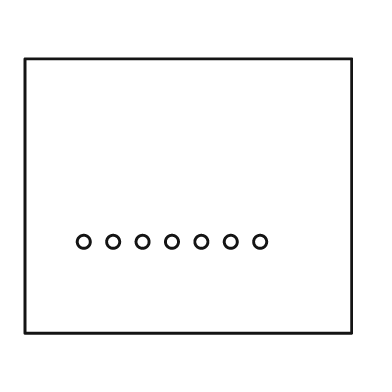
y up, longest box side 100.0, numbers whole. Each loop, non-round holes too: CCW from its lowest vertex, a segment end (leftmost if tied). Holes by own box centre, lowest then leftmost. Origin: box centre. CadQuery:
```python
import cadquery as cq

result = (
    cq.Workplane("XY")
    .moveTo(-50.0, -42.0)
    .lineTo(50.0, -42.0)
    .lineTo(50.0, 42.0)
    .lineTo(-50.0, 42.0)
    .close()
    .moveTo(-32.0, -14.0)
    .circle(2.0)
    .moveTo(-23.0, -14.0)
    .circle(2.0)
    .moveTo(-14.0, -14.0)
    .circle(2.0)
    .moveTo(-5.0, -14.0)
    .circle(2.0)
    .moveTo(4.0, -14.0)
    .circle(2.0)
    .moveTo(13.0, -14.0)
    .circle(2.0)
    .moveTo(22.0, -14.0)
    .circle(2.0)
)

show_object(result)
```